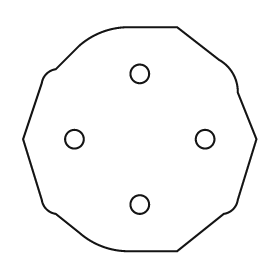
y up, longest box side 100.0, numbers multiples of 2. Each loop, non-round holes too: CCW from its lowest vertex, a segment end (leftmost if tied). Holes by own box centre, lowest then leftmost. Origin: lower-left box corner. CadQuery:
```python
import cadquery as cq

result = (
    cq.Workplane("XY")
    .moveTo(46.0, 0.0)
    .lineTo(66.0, 0.0)
    .lineTo(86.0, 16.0)
    .threePointArc((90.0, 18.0), (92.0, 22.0))
    .lineTo(100.0, 48.0)
    .lineTo(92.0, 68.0)
    .threePointArc((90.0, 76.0), (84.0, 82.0))
    .lineTo(66.0, 96.0)
    .lineTo(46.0, 96.0)
    .threePointArc((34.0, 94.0), (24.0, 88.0))
    .lineTo(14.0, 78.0)
    .threePointArc((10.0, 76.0), (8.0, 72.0))
    .lineTo(0.0, 48.0)
    .lineTo(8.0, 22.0)
    .threePointArc((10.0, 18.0), (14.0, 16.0))
    .lineTo(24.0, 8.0)
    .threePointArc((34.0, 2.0), (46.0, 0.0))
    .close()
    .moveTo(50.0, 20.0)
    .circle(4.0)
    .moveTo(22.0, 48.0)
    .circle(4.0)
    .moveTo(78.0, 48.0)
    .circle(4.0)
    .moveTo(50.0, 76.0)
    .circle(4.0)
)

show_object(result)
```